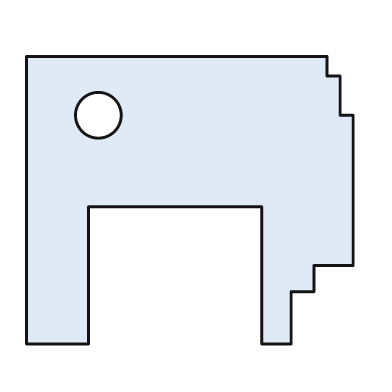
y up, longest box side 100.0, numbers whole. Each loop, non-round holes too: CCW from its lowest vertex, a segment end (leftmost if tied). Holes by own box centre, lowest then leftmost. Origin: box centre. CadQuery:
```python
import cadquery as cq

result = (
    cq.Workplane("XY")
    .moveTo(-50.0, -44.0)
    .lineTo(-31.0, -44.0)
    .lineTo(-31.0, -2.0)
    .lineTo(22.0, -2.0)
    .lineTo(22.0, -44.0)
    .lineTo(31.0, -44.0)
    .lineTo(31.0, -28.0)
    .lineTo(38.0, -28.0)
    .lineTo(38.0, -20.0)
    .lineTo(50.0, -20.0)
    .lineTo(50.0, 26.0)
    .lineTo(46.0, 26.0)
    .lineTo(46.0, 38.0)
    .lineTo(42.0, 38.0)
    .lineTo(42.0, 44.0)
    .lineTo(-50.0, 44.0)
    .close()
    .moveTo(-28.0, 26.0)
    .circle(7.0)
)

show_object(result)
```